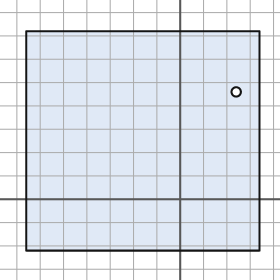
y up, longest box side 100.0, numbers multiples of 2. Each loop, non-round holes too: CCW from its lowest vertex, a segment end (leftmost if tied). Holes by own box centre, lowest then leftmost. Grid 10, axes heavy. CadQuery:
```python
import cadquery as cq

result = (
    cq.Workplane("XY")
    .moveTo(-66.0, -22.0)
    .lineTo(34.0, -22.0)
    .lineTo(34.0, 72.0)
    .lineTo(-66.0, 72.0)
    .close()
    .moveTo(24.0, 46.0)
    .circle(2.0)
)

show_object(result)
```